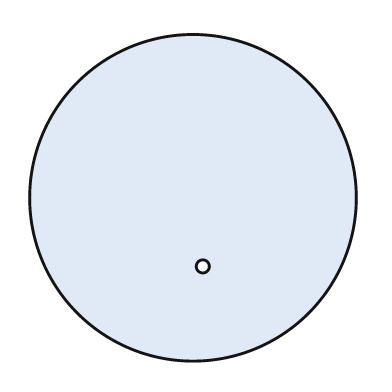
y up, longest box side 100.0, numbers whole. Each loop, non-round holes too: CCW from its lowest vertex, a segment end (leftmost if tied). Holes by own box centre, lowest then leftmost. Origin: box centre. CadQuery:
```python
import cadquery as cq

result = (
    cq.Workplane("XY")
    .moveTo(0.0, 0.0)
    .circle(50.0)
    .moveTo(3.0, -21.0)
    .circle(2.0)
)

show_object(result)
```